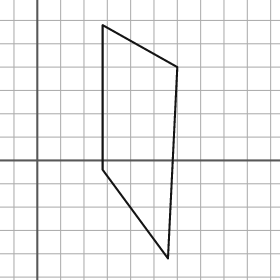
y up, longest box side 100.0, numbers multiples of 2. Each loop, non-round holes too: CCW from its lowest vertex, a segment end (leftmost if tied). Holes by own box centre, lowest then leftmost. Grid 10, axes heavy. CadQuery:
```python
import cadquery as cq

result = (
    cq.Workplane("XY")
    .moveTo(56.0, -42.0)
    .lineTo(60.0, 40.0)
    .lineTo(28.0, 58.0)
    .lineTo(28.0, -4.0)
    .close()
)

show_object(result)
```